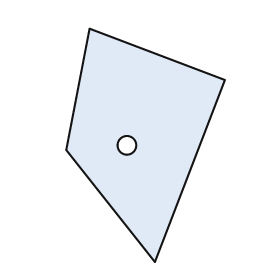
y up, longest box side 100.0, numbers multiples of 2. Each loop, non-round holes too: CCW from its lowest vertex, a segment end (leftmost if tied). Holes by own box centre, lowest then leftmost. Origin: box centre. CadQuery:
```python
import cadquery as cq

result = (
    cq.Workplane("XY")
    .moveTo(4.0, -50.0)
    .lineTo(34.0, 28.0)
    .lineTo(-24.0, 50.0)
    .lineTo(-34.0, -2.0)
    .close()
    .moveTo(-8.0, 0.0)
    .circle(4.0)
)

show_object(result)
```